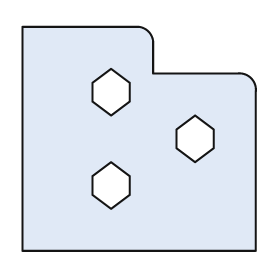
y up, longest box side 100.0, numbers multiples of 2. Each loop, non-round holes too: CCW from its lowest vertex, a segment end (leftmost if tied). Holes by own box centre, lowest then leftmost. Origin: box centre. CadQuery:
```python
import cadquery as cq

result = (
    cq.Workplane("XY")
    .moveTo(-50.0, -48.0)
    .lineTo(50.0, -48.0)
    .lineTo(50.0, 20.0)
    .threePointArc((48.0, 26.0), (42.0, 28.0))
    .lineTo(6.0, 28.0)
    .lineTo(6.0, 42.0)
    .threePointArc((4.0, 46.0), (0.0, 48.0))
    .lineTo(-50.0, 48.0)
    .close()
    .moveTo(-12.0, -30.0)
    .lineTo(-4.0, -24.0)
    .lineTo(-4.0, -16.0)
    .lineTo(-12.0, -10.0)
    .lineTo(-20.0, -16.0)
    .lineTo(-20.0, -24.0)
    .close()
    .moveTo(24.0, -10.0)
    .lineTo(32.0, -4.0)
    .lineTo(32.0, 4.0)
    .lineTo(24.0, 10.0)
    .lineTo(16.0, 4.0)
    .lineTo(16.0, -4.0)
    .close()
    .moveTo(-12.0, 10.0)
    .lineTo(-4.0, 16.0)
    .lineTo(-4.0, 24.0)
    .lineTo(-12.0, 30.0)
    .lineTo(-20.0, 24.0)
    .lineTo(-20.0, 16.0)
    .close()
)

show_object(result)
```